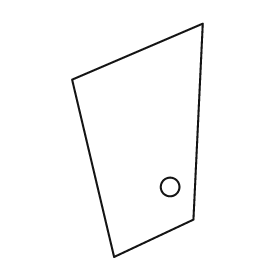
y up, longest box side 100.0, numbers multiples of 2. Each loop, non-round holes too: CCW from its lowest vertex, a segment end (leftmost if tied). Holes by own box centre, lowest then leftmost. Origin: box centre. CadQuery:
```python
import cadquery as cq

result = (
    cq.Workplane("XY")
    .moveTo(-10.0, -50.0)
    .lineTo(24.0, -34.0)
    .lineTo(28.0, 50.0)
    .lineTo(-28.0, 26.0)
    .close()
    .moveTo(14.0, -20.0)
    .circle(4.0)
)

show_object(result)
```